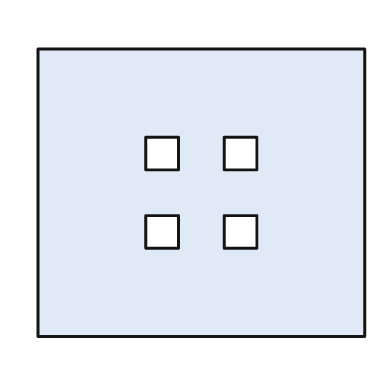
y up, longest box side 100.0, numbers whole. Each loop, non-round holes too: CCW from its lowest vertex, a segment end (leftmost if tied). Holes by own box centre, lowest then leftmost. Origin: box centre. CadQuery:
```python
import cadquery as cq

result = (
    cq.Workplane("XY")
    .moveTo(-50.0, -44.0)
    .lineTo(50.0, -44.0)
    .lineTo(50.0, 44.0)
    .lineTo(-50.0, 44.0)
    .close()
    .moveTo(-17.0, -17.0)
    .lineTo(-7.0, -17.0)
    .lineTo(-7.0, -7.0)
    .lineTo(-17.0, -7.0)
    .close()
    .moveTo(7.0, -17.0)
    .lineTo(17.0, -17.0)
    .lineTo(17.0, -7.0)
    .lineTo(7.0, -7.0)
    .close()
    .moveTo(-17.0, 7.0)
    .lineTo(-7.0, 7.0)
    .lineTo(-7.0, 17.0)
    .lineTo(-17.0, 17.0)
    .close()
    .moveTo(7.0, 7.0)
    .lineTo(17.0, 7.0)
    .lineTo(17.0, 17.0)
    .lineTo(7.0, 17.0)
    .close()
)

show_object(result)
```